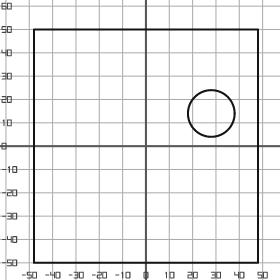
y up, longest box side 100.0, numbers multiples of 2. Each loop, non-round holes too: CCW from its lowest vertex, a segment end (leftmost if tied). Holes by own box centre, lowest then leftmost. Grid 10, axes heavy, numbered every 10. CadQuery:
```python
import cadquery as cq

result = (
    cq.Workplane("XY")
    .moveTo(-48.0, -50.0)
    .lineTo(48.0, -50.0)
    .lineTo(48.0, 50.0)
    .lineTo(-48.0, 50.0)
    .close()
    .moveTo(28.0, 14.0)
    .circle(10.0)
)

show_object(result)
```